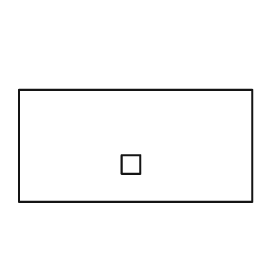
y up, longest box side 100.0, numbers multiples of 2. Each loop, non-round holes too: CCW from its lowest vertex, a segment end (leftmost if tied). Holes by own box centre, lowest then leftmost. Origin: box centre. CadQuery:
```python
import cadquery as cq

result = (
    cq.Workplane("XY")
    .moveTo(-50.0, -24.0)
    .lineTo(50.0, -24.0)
    .lineTo(50.0, 24.0)
    .lineTo(-50.0, 24.0)
    .close()
    .moveTo(-6.0, -12.0)
    .lineTo(2.0, -12.0)
    .lineTo(2.0, -4.0)
    .lineTo(-6.0, -4.0)
    .close()
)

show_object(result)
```